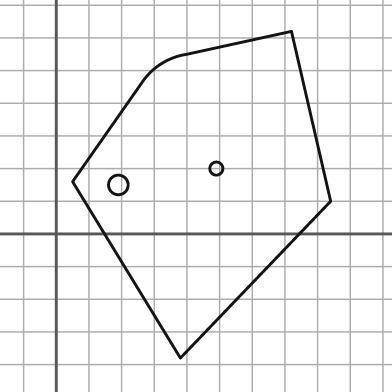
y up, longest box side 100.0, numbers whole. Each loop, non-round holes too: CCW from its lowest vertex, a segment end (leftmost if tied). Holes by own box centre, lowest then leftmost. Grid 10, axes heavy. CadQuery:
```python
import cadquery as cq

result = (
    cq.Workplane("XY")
    .moveTo(38.0, -38.0)
    .lineTo(84.0, 10.0)
    .lineTo(72.0, 62.0)
    .lineTo(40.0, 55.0)
    .threePointArc((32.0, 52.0), (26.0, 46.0))
    .lineTo(5.0, 16.0)
    .close()
    .moveTo(19.0, 15.0)
    .circle(3.0)
    .moveTo(49.0, 20.0)
    .circle(2.0)
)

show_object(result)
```